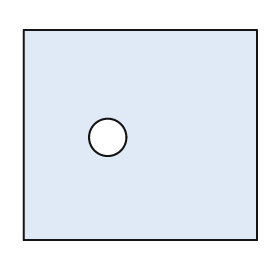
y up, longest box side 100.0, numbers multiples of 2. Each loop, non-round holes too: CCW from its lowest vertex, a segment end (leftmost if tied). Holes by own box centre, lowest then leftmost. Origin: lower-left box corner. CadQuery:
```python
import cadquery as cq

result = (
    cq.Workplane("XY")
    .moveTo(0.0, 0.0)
    .lineTo(100.0, 0.0)
    .lineTo(100.0, 90.0)
    .lineTo(0.0, 90.0)
    .close()
    .moveTo(36.0, 44.0)
    .circle(8.0)
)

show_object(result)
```